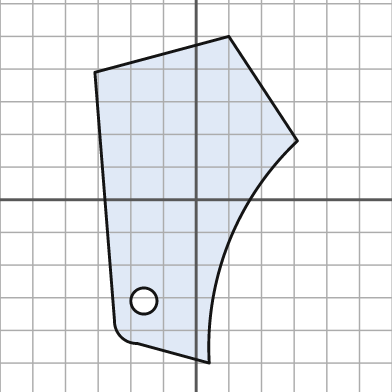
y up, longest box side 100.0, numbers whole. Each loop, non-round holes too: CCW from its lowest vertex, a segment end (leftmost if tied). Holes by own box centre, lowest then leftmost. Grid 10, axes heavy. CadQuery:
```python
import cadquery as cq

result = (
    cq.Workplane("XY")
    .moveTo(4.0, -50.0)
    .threePointArc((10.0, -13.0), (31.0, 18.0))
    .lineTo(10.0, 50.0)
    .lineTo(-31.0, 39.0)
    .lineTo(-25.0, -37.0)
    .threePointArc((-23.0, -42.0), (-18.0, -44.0))
    .close()
    .moveTo(-16.0, -31.0)
    .circle(4.0)
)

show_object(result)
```